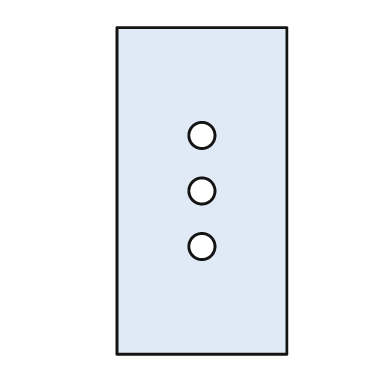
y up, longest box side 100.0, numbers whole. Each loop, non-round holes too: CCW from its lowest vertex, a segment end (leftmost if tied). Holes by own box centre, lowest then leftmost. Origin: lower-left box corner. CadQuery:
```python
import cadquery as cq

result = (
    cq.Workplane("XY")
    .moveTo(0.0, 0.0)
    .lineTo(52.0, 0.0)
    .lineTo(52.0, 100.0)
    .lineTo(0.0, 100.0)
    .close()
    .moveTo(26.0, 33.0)
    .circle(4.0)
    .moveTo(26.0, 50.0)
    .circle(4.0)
    .moveTo(26.0, 67.0)
    .circle(4.0)
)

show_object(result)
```